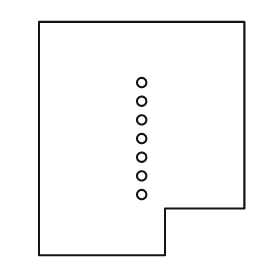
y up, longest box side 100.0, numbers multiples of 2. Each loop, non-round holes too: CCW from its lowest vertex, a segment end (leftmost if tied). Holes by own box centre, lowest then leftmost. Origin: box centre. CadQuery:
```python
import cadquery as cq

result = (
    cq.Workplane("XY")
    .moveTo(-44.0, -50.0)
    .lineTo(10.0, -50.0)
    .lineTo(10.0, -30.0)
    .lineTo(44.0, -30.0)
    .lineTo(44.0, 50.0)
    .lineTo(-44.0, 50.0)
    .close()
    .moveTo(0.0, -24.0)
    .circle(2.0)
    .moveTo(0.0, -16.0)
    .circle(2.0)
    .moveTo(0.0, -8.0)
    .circle(2.0)
    .moveTo(0.0, 0.0)
    .circle(2.0)
    .moveTo(0.0, 8.0)
    .circle(2.0)
    .moveTo(0.0, 16.0)
    .circle(2.0)
    .moveTo(0.0, 24.0)
    .circle(2.0)
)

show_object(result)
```